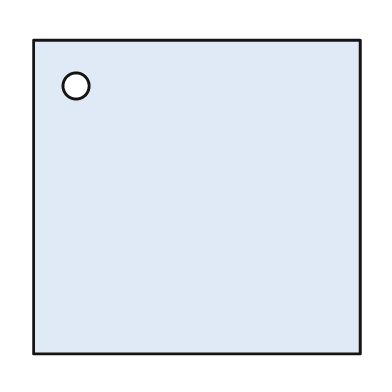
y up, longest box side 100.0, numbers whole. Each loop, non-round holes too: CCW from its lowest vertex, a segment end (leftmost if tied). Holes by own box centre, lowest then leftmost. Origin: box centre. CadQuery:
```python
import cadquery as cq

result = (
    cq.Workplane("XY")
    .moveTo(-50.0, -48.0)
    .lineTo(50.0, -48.0)
    .lineTo(50.0, 48.0)
    .lineTo(-50.0, 48.0)
    .close()
    .moveTo(-37.0, 34.0)
    .circle(4.0)
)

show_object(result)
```